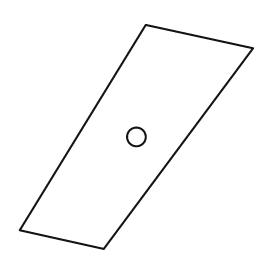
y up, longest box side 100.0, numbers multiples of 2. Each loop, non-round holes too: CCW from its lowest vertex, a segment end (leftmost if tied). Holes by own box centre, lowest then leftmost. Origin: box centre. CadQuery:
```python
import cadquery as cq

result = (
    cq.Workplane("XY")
    .moveTo(-14.0, -48.0)
    .lineTo(50.0, 38.0)
    .lineTo(4.0, 48.0)
    .lineTo(-50.0, -40.0)
    .close()
    .moveTo(0.0, 0.0)
    .circle(4.0)
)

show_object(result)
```